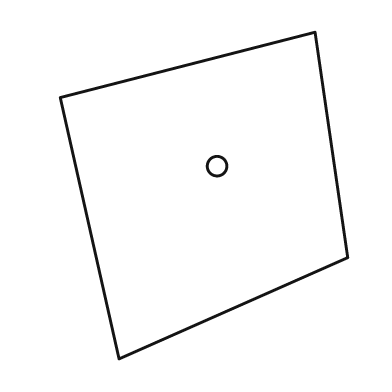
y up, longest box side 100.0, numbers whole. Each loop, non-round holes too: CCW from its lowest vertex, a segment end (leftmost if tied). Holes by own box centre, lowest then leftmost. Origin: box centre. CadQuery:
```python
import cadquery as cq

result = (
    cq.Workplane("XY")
    .moveTo(-26.0, -50.0)
    .lineTo(44.0, -19.0)
    .lineTo(34.0, 50.0)
    .lineTo(-44.0, 30.0)
    .close()
    .moveTo(4.0, 9.0)
    .circle(3.0)
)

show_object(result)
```